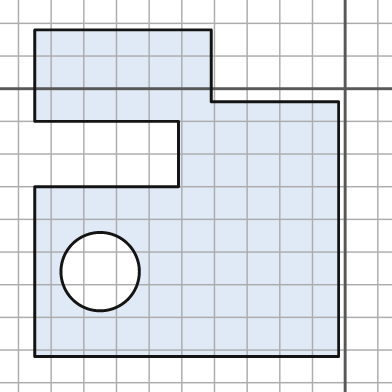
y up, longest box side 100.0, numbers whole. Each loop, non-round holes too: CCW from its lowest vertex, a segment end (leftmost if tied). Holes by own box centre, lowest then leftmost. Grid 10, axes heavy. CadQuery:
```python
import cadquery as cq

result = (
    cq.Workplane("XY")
    .moveTo(-95.0, -82.0)
    .lineTo(-2.0, -82.0)
    .lineTo(-2.0, -4.0)
    .lineTo(-41.0, -4.0)
    .lineTo(-41.0, 18.0)
    .lineTo(-95.0, 18.0)
    .lineTo(-95.0, -10.0)
    .lineTo(-51.0, -10.0)
    .lineTo(-51.0, -30.0)
    .lineTo(-95.0, -30.0)
    .close()
    .moveTo(-75.0, -56.0)
    .circle(12.0)
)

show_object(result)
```